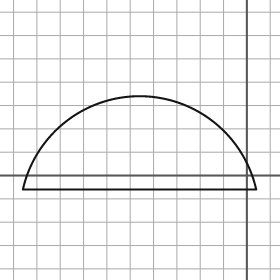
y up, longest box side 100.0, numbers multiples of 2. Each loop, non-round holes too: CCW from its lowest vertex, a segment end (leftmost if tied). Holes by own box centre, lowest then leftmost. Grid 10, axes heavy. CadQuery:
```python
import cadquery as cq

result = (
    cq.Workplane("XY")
    .moveTo(-96.0, -6.0)
    .lineTo(4.0, -6.0)
    .threePointArc((-46.0, 34.0), (-96.0, -6.0))
    .close()
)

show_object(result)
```